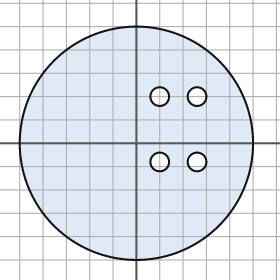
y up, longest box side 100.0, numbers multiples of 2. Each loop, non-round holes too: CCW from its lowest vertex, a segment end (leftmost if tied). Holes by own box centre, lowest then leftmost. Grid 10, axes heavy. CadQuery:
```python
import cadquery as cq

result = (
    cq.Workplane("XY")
    .moveTo(0.0, 0.0)
    .circle(50.0)
    .moveTo(10.0, -8.0)
    .circle(4.0)
    .moveTo(26.0, -8.0)
    .circle(4.0)
    .moveTo(10.0, 20.0)
    .circle(4.0)
    .moveTo(26.0, 20.0)
    .circle(4.0)
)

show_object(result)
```